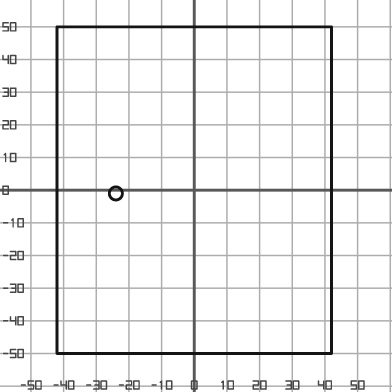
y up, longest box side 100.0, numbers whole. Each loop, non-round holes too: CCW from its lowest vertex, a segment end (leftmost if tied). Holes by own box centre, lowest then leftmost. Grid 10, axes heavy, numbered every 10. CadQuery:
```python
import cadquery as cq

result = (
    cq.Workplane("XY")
    .moveTo(-42.0, -50.0)
    .lineTo(42.0, -50.0)
    .lineTo(42.0, 50.0)
    .lineTo(-42.0, 50.0)
    .close()
    .moveTo(-24.0, -1.0)
    .circle(2.0)
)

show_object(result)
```